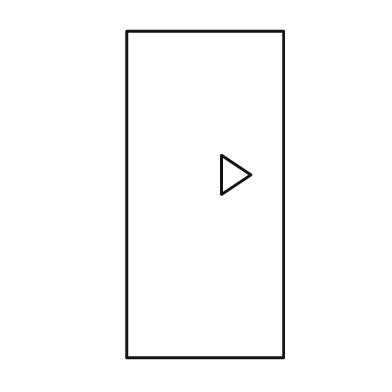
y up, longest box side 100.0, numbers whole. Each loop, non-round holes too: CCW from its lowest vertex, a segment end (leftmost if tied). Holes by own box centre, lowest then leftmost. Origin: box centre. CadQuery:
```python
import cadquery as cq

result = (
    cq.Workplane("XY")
    .moveTo(-24.0, -50.0)
    .lineTo(24.0, -50.0)
    .lineTo(24.0, 50.0)
    .lineTo(-24.0, 50.0)
    .close()
    .moveTo(5.0, 0.0)
    .lineTo(14.0, 6.0)
    .lineTo(5.0, 12.0)
    .close()
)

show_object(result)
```